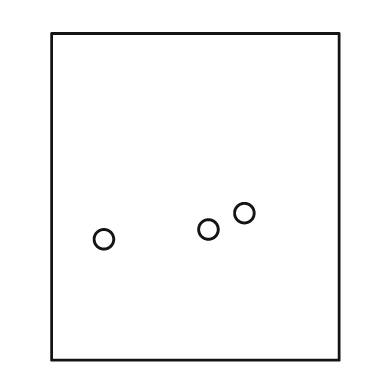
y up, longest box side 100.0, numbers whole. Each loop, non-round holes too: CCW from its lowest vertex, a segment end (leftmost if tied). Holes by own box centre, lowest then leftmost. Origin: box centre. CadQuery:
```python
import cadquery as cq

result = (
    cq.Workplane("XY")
    .moveTo(-44.0, -50.0)
    .lineTo(44.0, -50.0)
    .lineTo(44.0, 50.0)
    .lineTo(-44.0, 50.0)
    .close()
    .moveTo(-28.0, -13.0)
    .circle(3.0)
    .moveTo(4.0, -10.0)
    .circle(3.0)
    .moveTo(15.0, -5.0)
    .circle(3.0)
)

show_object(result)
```